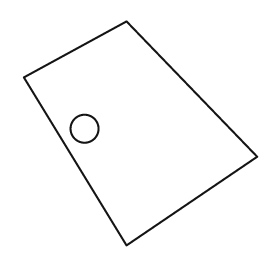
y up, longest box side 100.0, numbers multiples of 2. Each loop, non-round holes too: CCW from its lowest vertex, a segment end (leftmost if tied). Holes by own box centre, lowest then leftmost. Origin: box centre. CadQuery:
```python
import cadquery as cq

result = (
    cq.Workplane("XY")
    .moveTo(-6.0, -48.0)
    .lineTo(50.0, -10.0)
    .lineTo(-6.0, 48.0)
    .lineTo(-50.0, 24.0)
    .close()
    .moveTo(-24.0, 2.0)
    .circle(6.0)
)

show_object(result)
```